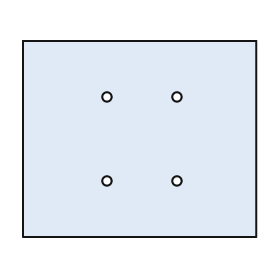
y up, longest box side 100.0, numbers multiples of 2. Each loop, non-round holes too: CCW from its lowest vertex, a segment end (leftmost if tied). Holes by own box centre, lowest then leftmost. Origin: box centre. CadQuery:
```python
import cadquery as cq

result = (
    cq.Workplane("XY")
    .moveTo(-50.0, -42.0)
    .lineTo(50.0, -42.0)
    .lineTo(50.0, 42.0)
    .lineTo(-50.0, 42.0)
    .close()
    .moveTo(-14.0, -18.0)
    .circle(2.0)
    .moveTo(16.0, -18.0)
    .circle(2.0)
    .moveTo(-14.0, 18.0)
    .circle(2.0)
    .moveTo(16.0, 18.0)
    .circle(2.0)
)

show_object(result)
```